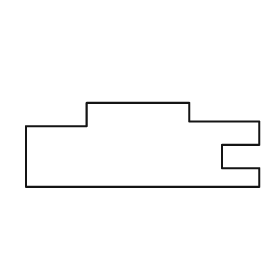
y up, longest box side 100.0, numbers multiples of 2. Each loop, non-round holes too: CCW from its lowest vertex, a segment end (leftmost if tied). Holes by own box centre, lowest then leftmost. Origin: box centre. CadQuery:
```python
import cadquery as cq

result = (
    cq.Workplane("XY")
    .moveTo(-50.0, -18.0)
    .lineTo(50.0, -18.0)
    .lineTo(50.0, -10.0)
    .lineTo(34.0, -10.0)
    .lineTo(34.0, 0.0)
    .lineTo(50.0, 0.0)
    .lineTo(50.0, 10.0)
    .lineTo(20.0, 10.0)
    .lineTo(20.0, 18.0)
    .lineTo(-24.0, 18.0)
    .lineTo(-24.0, 8.0)
    .lineTo(-50.0, 8.0)
    .close()
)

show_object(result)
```